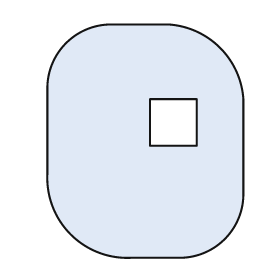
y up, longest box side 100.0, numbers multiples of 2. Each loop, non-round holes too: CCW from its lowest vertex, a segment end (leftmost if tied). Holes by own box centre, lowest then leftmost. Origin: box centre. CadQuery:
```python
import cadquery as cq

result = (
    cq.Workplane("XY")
    .moveTo(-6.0, -50.0)
    .lineTo(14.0, -50.0)
    .threePointArc((34.0, -42.0), (42.0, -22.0))
    .lineTo(42.0, 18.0)
    .threePointArc((32.0, 40.0), (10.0, 50.0))
    .lineTo(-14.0, 50.0)
    .threePointArc((-34.0, 42.0), (-42.0, 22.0))
    .lineTo(-42.0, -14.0)
    .threePointArc((-32.0, -40.0), (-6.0, -50.0))
    .close()
    .moveTo(2.0, -2.0)
    .lineTo(22.0, -2.0)
    .lineTo(22.0, 18.0)
    .lineTo(2.0, 18.0)
    .close()
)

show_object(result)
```